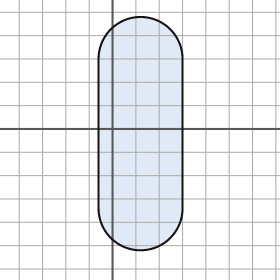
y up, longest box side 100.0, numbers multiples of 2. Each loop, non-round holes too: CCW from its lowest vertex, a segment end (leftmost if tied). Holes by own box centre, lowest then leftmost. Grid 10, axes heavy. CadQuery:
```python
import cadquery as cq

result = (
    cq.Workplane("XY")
    .moveTo(-6.0, -34.0)
    .threePointArc((12.0, -52.0), (30.0, -34.0))
    .lineTo(30.0, 30.0)
    .threePointArc((12.0, 48.0), (-6.0, 30.0))
    .close()
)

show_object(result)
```